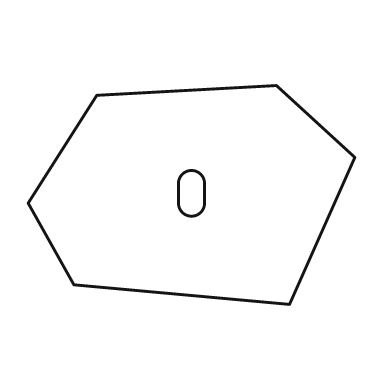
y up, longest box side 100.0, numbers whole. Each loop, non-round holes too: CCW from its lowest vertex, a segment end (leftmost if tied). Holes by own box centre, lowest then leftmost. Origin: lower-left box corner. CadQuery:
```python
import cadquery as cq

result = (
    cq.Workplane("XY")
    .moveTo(80.0, 0.0)
    .lineTo(100.0, 45.0)
    .lineTo(76.0, 67.0)
    .lineTo(21.0, 64.0)
    .lineTo(0.0, 31.0)
    .lineTo(14.0, 6.0)
    .close()
    .moveTo(46.0, 31.0)
    .threePointArc((50.0, 27.0), (54.0, 31.0))
    .lineTo(54.0, 37.0)
    .threePointArc((50.0, 41.0), (46.0, 37.0))
    .close()
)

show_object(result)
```